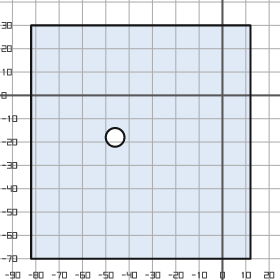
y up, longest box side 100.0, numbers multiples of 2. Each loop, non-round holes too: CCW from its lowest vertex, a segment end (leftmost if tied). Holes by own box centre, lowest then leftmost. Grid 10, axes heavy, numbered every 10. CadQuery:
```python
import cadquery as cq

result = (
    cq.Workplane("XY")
    .moveTo(-82.0, -70.0)
    .lineTo(12.0, -70.0)
    .lineTo(12.0, 30.0)
    .lineTo(-82.0, 30.0)
    .close()
    .moveTo(-46.0, -18.0)
    .circle(4.0)
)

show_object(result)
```